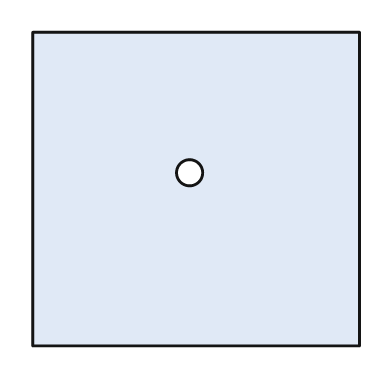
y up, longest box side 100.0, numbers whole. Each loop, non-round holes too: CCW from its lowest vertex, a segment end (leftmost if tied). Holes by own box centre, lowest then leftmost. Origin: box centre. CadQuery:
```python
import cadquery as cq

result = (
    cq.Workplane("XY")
    .moveTo(-50.0, -48.0)
    .lineTo(50.0, -48.0)
    .lineTo(50.0, 48.0)
    .lineTo(-50.0, 48.0)
    .close()
    .moveTo(-2.0, 5.0)
    .circle(4.0)
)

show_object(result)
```